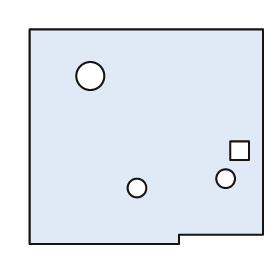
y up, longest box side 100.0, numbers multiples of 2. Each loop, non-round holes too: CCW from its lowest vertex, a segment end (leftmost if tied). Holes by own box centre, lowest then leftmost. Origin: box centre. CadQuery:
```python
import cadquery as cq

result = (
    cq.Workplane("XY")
    .moveTo(-50.0, -46.0)
    .lineTo(14.0, -46.0)
    .lineTo(14.0, -42.0)
    .lineTo(50.0, -42.0)
    .lineTo(50.0, 46.0)
    .lineTo(-50.0, 46.0)
    .close()
    .moveTo(-4.0, -22.0)
    .circle(4.0)
    .moveTo(34.0, -18.0)
    .circle(4.0)
    .moveTo(36.0, -10.0)
    .lineTo(44.0, -10.0)
    .lineTo(44.0, -2.0)
    .lineTo(36.0, -2.0)
    .close()
    .moveTo(-24.0, 26.0)
    .circle(6.0)
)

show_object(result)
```